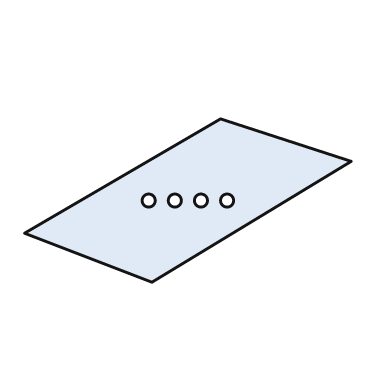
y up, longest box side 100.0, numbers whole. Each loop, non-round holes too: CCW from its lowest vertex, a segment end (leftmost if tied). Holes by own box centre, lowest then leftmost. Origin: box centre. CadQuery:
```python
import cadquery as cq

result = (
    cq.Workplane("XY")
    .moveTo(-11.0, -25.0)
    .lineTo(50.0, 12.0)
    .lineTo(10.0, 25.0)
    .lineTo(-50.0, -10.0)
    .close()
    .moveTo(-12.0, 0.0)
    .circle(2.0)
    .moveTo(-4.0, 0.0)
    .circle(2.0)
    .moveTo(4.0, 0.0)
    .circle(2.0)
    .moveTo(12.0, 0.0)
    .circle(2.0)
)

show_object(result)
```